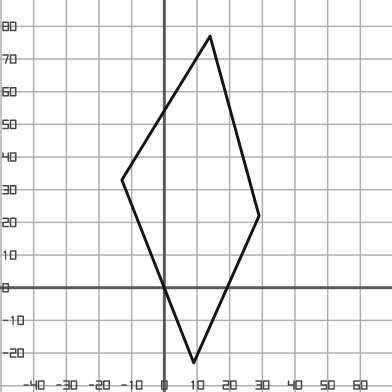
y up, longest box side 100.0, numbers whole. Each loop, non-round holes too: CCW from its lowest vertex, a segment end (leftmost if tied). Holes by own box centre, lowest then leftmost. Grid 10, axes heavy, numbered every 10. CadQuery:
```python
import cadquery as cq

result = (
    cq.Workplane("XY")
    .moveTo(9.0, -23.0)
    .lineTo(29.0, 22.0)
    .lineTo(14.0, 77.0)
    .lineTo(-13.0, 33.0)
    .close()
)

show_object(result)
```